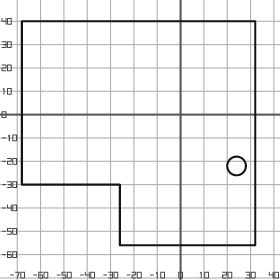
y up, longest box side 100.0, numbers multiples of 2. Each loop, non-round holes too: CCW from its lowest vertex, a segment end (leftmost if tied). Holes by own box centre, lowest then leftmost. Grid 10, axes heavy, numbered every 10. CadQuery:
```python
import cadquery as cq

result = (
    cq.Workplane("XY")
    .moveTo(-26.0, -56.0)
    .lineTo(32.0, -56.0)
    .lineTo(32.0, 40.0)
    .lineTo(-68.0, 40.0)
    .lineTo(-68.0, -30.0)
    .lineTo(-26.0, -30.0)
    .close()
    .moveTo(24.0, -22.0)
    .circle(4.0)
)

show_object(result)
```